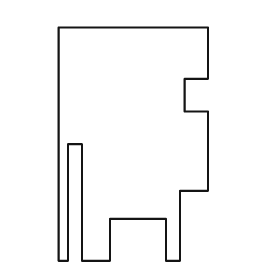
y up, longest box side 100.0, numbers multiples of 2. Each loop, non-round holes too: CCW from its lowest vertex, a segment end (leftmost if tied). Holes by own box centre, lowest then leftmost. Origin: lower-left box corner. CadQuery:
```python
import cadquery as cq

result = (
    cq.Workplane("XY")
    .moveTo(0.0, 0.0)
    .lineTo(4.0, 0.0)
    .lineTo(4.0, 50.0)
    .lineTo(10.0, 50.0)
    .lineTo(10.0, 0.0)
    .lineTo(22.0, 0.0)
    .lineTo(22.0, 18.0)
    .lineTo(46.0, 18.0)
    .lineTo(46.0, 0.0)
    .lineTo(52.0, 0.0)
    .lineTo(52.0, 30.0)
    .lineTo(64.0, 30.0)
    .lineTo(64.0, 64.0)
    .lineTo(54.0, 64.0)
    .lineTo(54.0, 78.0)
    .lineTo(64.0, 78.0)
    .lineTo(64.0, 100.0)
    .lineTo(0.0, 100.0)
    .close()
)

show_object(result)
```